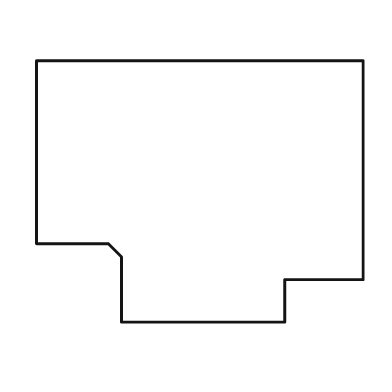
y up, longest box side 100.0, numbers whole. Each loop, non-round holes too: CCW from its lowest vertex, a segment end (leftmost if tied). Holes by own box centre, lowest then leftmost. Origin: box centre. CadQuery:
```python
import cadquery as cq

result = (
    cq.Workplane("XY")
    .moveTo(-24.0, -40.0)
    .lineTo(26.0, -40.0)
    .lineTo(26.0, -27.0)
    .lineTo(50.0, -27.0)
    .lineTo(50.0, 40.0)
    .lineTo(-50.0, 40.0)
    .lineTo(-50.0, -16.0)
    .lineTo(-28.0, -16.0)
    .lineTo(-24.0, -20.0)
    .close()
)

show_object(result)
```